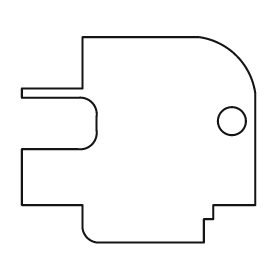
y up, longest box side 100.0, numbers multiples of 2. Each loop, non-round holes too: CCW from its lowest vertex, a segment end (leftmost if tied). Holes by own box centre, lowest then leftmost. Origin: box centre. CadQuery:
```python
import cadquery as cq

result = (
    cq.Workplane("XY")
    .moveTo(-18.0, -44.0)
    .lineTo(28.0, -44.0)
    .lineTo(28.0, -34.0)
    .lineTo(32.0, -34.0)
    .lineTo(32.0, -28.0)
    .lineTo(50.0, -28.0)
    .lineTo(50.0, 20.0)
    .threePointArc((42.0, 36.0), (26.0, 44.0))
    .lineTo(-24.0, 44.0)
    .lineTo(-24.0, 22.0)
    .lineTo(-50.0, 22.0)
    .lineTo(-50.0, 18.0)
    .lineTo(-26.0, 18.0)
    .threePointArc((-20.0, 16.0), (-18.0, 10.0))
    .lineTo(-18.0, 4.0)
    .threePointArc((-20.0, -2.0), (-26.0, -4.0))
    .lineTo(-50.0, -4.0)
    .lineTo(-50.0, -28.0)
    .lineTo(-24.0, -28.0)
    .lineTo(-24.0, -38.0)
    .threePointArc((-22.0, -42.0), (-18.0, -44.0))
    .close()
    .moveTo(40.0, 8.0)
    .circle(6.0)
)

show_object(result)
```